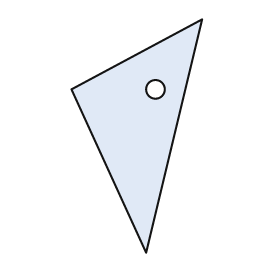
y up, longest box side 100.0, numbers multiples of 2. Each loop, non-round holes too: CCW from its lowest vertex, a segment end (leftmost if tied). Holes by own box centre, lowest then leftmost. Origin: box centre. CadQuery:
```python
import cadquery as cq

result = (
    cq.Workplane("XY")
    .moveTo(4.0, -50.0)
    .lineTo(28.0, 50.0)
    .lineTo(-28.0, 20.0)
    .close()
    .moveTo(8.0, 20.0)
    .circle(4.0)
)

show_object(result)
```